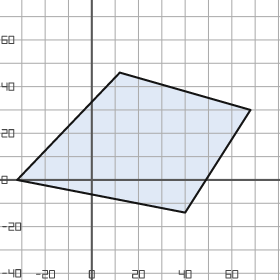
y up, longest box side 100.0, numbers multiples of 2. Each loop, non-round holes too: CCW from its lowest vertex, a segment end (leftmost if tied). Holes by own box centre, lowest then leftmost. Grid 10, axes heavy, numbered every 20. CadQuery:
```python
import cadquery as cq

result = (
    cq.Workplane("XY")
    .moveTo(40.0, -14.0)
    .lineTo(68.0, 30.0)
    .lineTo(12.0, 46.0)
    .lineTo(-32.0, 0.0)
    .close()
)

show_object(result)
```